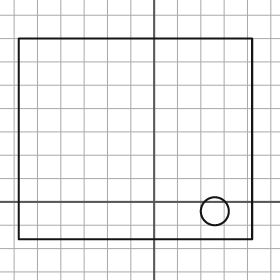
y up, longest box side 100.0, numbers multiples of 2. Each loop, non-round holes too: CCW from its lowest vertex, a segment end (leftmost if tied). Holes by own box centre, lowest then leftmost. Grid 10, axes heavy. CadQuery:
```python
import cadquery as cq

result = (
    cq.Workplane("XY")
    .moveTo(-58.0, -16.0)
    .lineTo(42.0, -16.0)
    .lineTo(42.0, 70.0)
    .lineTo(-58.0, 70.0)
    .close()
    .moveTo(26.0, -4.0)
    .circle(6.0)
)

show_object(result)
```